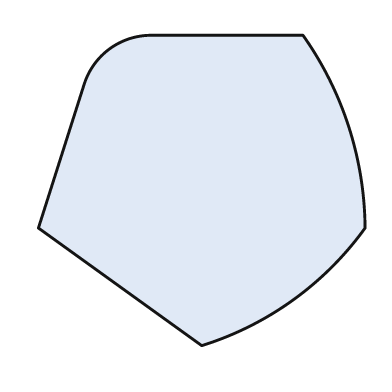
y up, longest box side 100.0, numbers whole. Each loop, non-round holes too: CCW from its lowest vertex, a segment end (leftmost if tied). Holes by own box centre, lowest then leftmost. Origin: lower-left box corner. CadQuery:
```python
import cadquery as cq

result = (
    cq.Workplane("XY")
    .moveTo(50.0, 0.0)
    .threePointArc((78.0, 14.0), (100.0, 36.0))
    .threePointArc((95.0, 67.0), (81.0, 95.0))
    .lineTo(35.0, 95.0)
    .threePointArc((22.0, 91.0), (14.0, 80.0))
    .lineTo(0.0, 36.0)
    .close()
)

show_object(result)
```